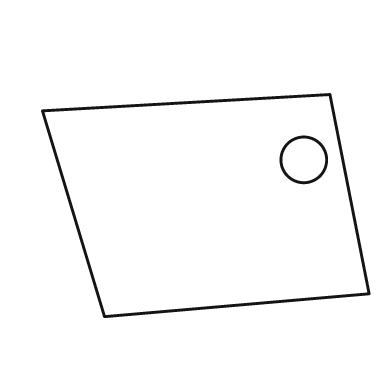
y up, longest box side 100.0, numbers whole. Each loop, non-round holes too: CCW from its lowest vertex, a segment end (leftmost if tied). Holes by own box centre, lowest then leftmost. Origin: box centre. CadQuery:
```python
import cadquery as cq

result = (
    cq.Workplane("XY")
    .moveTo(-31.0, -34.0)
    .lineTo(50.0, -27.0)
    .lineTo(38.0, 34.0)
    .lineTo(-50.0, 29.0)
    .close()
    .moveTo(30.0, 14.0)
    .circle(7.0)
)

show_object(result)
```